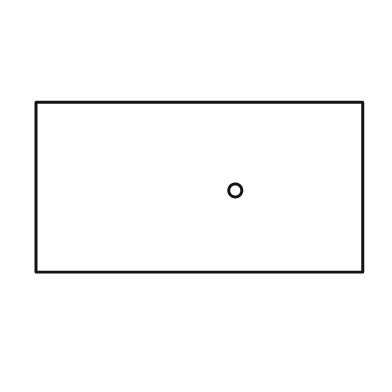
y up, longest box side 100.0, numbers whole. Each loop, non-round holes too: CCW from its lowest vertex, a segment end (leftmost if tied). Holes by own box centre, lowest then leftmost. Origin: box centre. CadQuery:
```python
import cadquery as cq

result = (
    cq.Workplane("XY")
    .moveTo(-50.0, -26.0)
    .lineTo(50.0, -26.0)
    .lineTo(50.0, 26.0)
    .lineTo(-50.0, 26.0)
    .close()
    .moveTo(11.0, -1.0)
    .circle(2.0)
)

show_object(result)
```